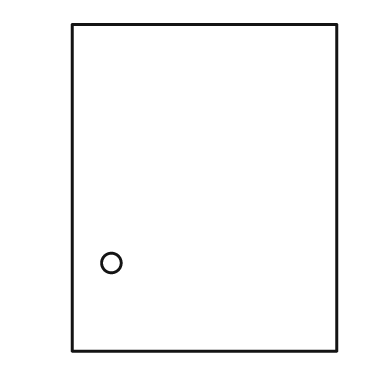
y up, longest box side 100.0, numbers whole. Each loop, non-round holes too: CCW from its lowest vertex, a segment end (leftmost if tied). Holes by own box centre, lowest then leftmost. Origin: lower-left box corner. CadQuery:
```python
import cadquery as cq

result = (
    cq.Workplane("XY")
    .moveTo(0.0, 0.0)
    .lineTo(81.0, 0.0)
    .lineTo(81.0, 100.0)
    .lineTo(0.0, 100.0)
    .close()
    .moveTo(12.0, 27.0)
    .circle(3.0)
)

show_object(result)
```